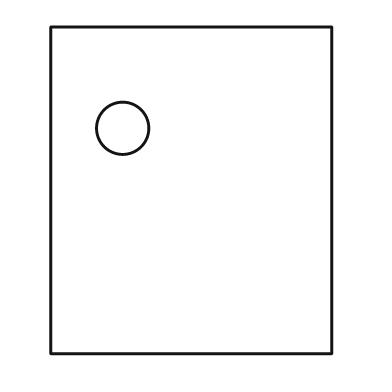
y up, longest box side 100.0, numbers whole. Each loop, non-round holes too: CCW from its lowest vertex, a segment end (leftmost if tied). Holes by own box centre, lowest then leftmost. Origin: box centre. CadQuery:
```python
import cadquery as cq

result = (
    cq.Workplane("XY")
    .moveTo(-43.0, -50.0)
    .lineTo(43.0, -50.0)
    .lineTo(43.0, 50.0)
    .lineTo(-43.0, 50.0)
    .close()
    .moveTo(-21.0, 19.0)
    .circle(8.0)
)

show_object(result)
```